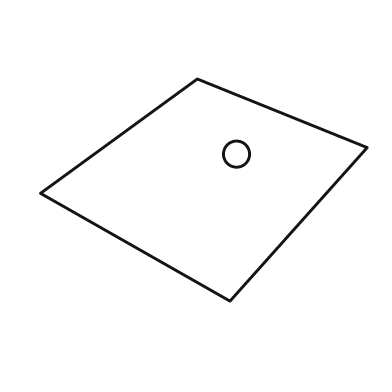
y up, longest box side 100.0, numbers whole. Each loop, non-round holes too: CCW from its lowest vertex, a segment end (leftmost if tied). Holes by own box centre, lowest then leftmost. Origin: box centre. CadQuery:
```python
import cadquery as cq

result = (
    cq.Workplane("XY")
    .moveTo(8.0, -34.0)
    .lineTo(50.0, 13.0)
    .lineTo(-2.0, 34.0)
    .lineTo(-50.0, -1.0)
    .close()
    .moveTo(10.0, 11.0)
    .circle(4.0)
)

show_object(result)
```